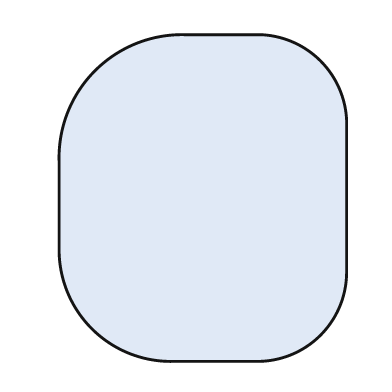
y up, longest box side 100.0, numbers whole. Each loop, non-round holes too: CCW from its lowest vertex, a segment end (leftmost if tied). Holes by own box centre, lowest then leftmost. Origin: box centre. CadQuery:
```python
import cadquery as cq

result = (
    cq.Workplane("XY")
    .moveTo(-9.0, -50.0)
    .lineTo(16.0, -50.0)
    .threePointArc((36.0, -42.0), (44.0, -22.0))
    .lineTo(44.0, 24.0)
    .threePointArc((36.0, 42.0), (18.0, 50.0))
    .lineTo(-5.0, 50.0)
    .threePointArc((-33.0, 39.0), (-44.0, 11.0))
    .lineTo(-44.0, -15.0)
    .threePointArc((-34.0, -40.0), (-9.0, -50.0))
    .close()
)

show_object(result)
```